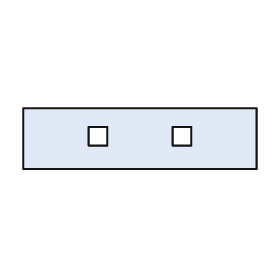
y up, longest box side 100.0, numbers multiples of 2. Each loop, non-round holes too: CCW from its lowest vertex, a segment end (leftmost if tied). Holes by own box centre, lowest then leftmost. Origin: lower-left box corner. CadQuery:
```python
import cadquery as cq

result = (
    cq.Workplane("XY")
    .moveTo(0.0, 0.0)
    .lineTo(100.0, 0.0)
    .lineTo(100.0, 26.0)
    .lineTo(0.0, 26.0)
    .close()
    .moveTo(28.0, 10.0)
    .lineTo(36.0, 10.0)
    .lineTo(36.0, 18.0)
    .lineTo(28.0, 18.0)
    .close()
    .moveTo(64.0, 10.0)
    .lineTo(72.0, 10.0)
    .lineTo(72.0, 18.0)
    .lineTo(64.0, 18.0)
    .close()
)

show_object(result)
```